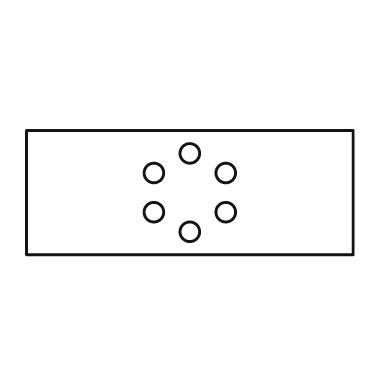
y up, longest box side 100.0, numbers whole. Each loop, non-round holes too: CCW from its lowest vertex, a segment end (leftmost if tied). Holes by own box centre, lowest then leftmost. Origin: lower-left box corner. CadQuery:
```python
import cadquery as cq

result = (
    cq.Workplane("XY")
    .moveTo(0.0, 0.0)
    .lineTo(100.0, 0.0)
    .lineTo(100.0, 38.0)
    .lineTo(0.0, 38.0)
    .close()
    .moveTo(50.0, 7.0)
    .circle(3.0)
    .moveTo(39.0, 13.0)
    .circle(3.0)
    .moveTo(61.0, 13.0)
    .circle(3.0)
    .moveTo(39.0, 25.0)
    .circle(3.0)
    .moveTo(61.0, 25.0)
    .circle(3.0)
    .moveTo(50.0, 31.0)
    .circle(3.0)
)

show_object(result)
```